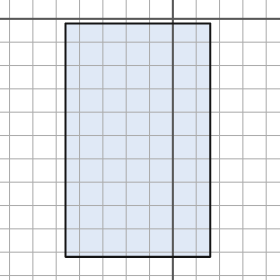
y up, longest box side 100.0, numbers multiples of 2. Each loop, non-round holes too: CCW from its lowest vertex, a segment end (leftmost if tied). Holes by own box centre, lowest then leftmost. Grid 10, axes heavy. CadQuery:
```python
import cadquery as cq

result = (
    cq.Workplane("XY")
    .moveTo(-46.0, -102.0)
    .lineTo(16.0, -102.0)
    .lineTo(16.0, -2.0)
    .lineTo(-46.0, -2.0)
    .close()
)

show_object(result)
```